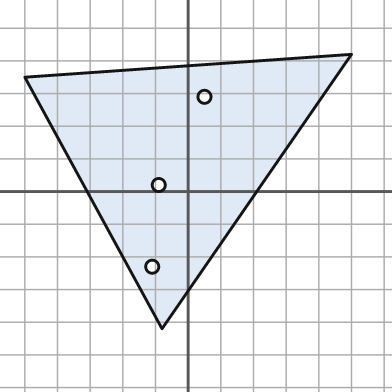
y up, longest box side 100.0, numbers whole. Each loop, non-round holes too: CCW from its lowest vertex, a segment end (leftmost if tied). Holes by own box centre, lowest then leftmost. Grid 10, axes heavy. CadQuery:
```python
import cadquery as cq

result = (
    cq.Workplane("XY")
    .moveTo(-8.0, -42.0)
    .lineTo(50.0, 42.0)
    .lineTo(-50.0, 35.0)
    .close()
    .moveTo(-11.0, -23.0)
    .circle(2.0)
    .moveTo(-9.0, 2.0)
    .circle(2.0)
    .moveTo(5.0, 29.0)
    .circle(2.0)
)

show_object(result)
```